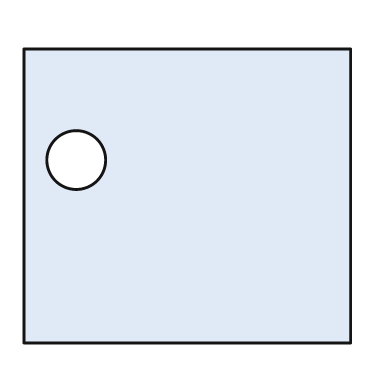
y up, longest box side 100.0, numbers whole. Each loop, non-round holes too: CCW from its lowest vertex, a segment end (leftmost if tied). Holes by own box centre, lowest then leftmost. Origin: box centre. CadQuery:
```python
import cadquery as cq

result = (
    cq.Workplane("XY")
    .moveTo(-50.0, -45.0)
    .lineTo(50.0, -45.0)
    .lineTo(50.0, 45.0)
    .lineTo(-50.0, 45.0)
    .close()
    .moveTo(-34.0, 11.0)
    .circle(9.0)
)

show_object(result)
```